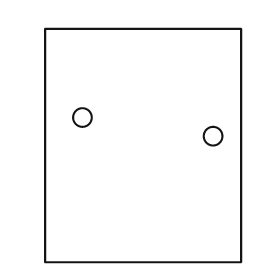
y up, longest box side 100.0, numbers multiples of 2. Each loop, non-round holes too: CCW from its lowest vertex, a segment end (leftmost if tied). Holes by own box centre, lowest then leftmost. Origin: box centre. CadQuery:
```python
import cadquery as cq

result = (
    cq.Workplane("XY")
    .moveTo(-42.0, -50.0)
    .lineTo(42.0, -50.0)
    .lineTo(42.0, 50.0)
    .lineTo(-42.0, 50.0)
    .close()
    .moveTo(30.0, 4.0)
    .circle(4.0)
    .moveTo(-26.0, 12.0)
    .circle(4.0)
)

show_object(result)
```